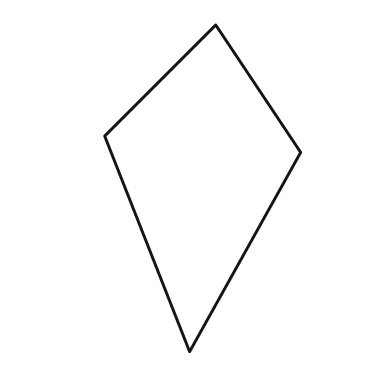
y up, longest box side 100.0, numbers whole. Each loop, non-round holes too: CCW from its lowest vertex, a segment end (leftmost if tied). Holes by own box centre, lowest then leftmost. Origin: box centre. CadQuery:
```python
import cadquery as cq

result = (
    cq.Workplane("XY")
    .moveTo(-4.0, -50.0)
    .lineTo(30.0, 11.0)
    .lineTo(4.0, 50.0)
    .lineTo(-30.0, 16.0)
    .close()
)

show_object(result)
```